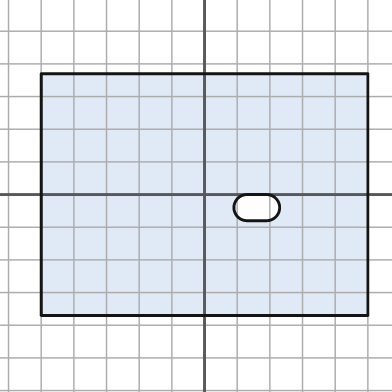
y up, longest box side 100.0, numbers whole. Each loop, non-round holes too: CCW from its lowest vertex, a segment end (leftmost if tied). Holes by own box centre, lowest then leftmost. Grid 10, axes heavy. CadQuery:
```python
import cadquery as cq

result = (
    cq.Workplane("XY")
    .moveTo(-50.0, -37.0)
    .lineTo(50.0, -37.0)
    .lineTo(50.0, 37.0)
    .lineTo(-50.0, 37.0)
    .close()
    .moveTo(13.0, -8.0)
    .lineTo(19.0, -8.0)
    .threePointArc((23.0, -4.0), (19.0, 0.0))
    .lineTo(13.0, 0.0)
    .threePointArc((9.0, -4.0), (13.0, -8.0))
    .close()
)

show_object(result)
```